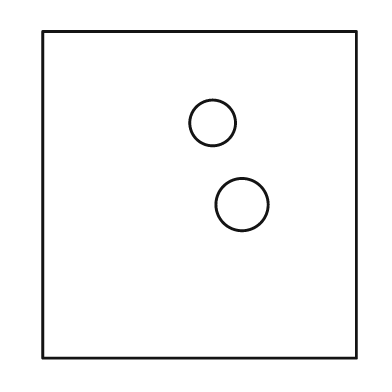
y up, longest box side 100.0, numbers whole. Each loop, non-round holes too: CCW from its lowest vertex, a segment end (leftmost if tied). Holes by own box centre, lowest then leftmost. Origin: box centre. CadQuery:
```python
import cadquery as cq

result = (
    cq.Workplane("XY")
    .moveTo(-48.0, -50.0)
    .lineTo(48.0, -50.0)
    .lineTo(48.0, 50.0)
    .lineTo(-48.0, 50.0)
    .close()
    .moveTo(13.0, -3.0)
    .circle(8.0)
    .moveTo(4.0, 22.0)
    .circle(7.0)
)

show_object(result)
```